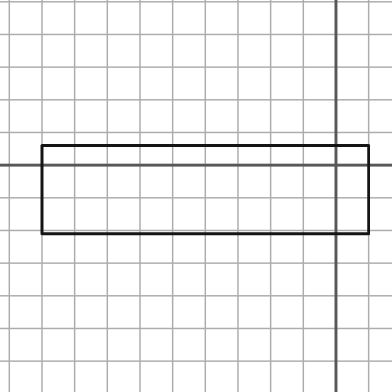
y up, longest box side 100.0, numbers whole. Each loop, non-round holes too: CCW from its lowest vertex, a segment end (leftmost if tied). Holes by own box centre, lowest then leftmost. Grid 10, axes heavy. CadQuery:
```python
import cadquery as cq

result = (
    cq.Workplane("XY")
    .moveTo(-90.0, -21.0)
    .lineTo(10.0, -21.0)
    .lineTo(10.0, 6.0)
    .lineTo(-90.0, 6.0)
    .close()
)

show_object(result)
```